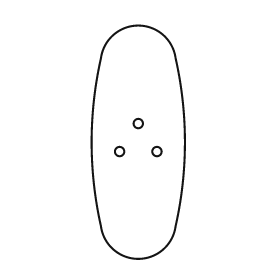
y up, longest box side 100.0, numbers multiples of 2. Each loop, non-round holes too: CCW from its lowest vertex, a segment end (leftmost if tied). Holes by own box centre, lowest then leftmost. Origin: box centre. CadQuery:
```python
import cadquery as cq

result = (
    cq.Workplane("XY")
    .moveTo(-16.0, -36.0)
    .threePointArc((0.0, -50.0), (16.0, -36.0))
    .threePointArc((20.0, 0.0), (16.0, 36.0))
    .threePointArc((0.0, 50.0), (-16.0, 36.0))
    .threePointArc((-20.0, 0.0), (-16.0, -36.0))
    .close()
    .moveTo(-8.0, -4.0)
    .circle(2.0)
    .moveTo(8.0, -4.0)
    .circle(2.0)
    .moveTo(0.0, 8.0)
    .circle(2.0)
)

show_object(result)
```